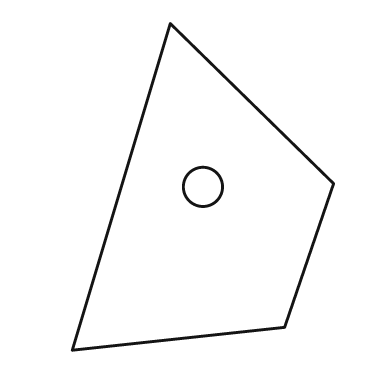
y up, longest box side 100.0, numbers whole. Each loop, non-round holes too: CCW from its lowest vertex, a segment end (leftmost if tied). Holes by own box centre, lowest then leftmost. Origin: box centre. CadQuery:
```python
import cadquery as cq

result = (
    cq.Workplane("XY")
    .moveTo(-40.0, -50.0)
    .lineTo(25.0, -43.0)
    .lineTo(40.0, 1.0)
    .lineTo(-10.0, 50.0)
    .close()
    .moveTo(0.0, 0.0)
    .circle(6.0)
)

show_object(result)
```